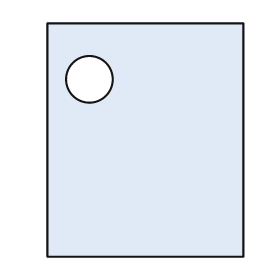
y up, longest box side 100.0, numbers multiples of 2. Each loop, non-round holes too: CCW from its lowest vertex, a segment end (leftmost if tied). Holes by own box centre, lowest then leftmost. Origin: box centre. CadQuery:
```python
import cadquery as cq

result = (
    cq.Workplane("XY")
    .moveTo(-42.0, -50.0)
    .lineTo(42.0, -50.0)
    .lineTo(42.0, 50.0)
    .lineTo(-42.0, 50.0)
    .close()
    .moveTo(-24.0, 26.0)
    .circle(10.0)
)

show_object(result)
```